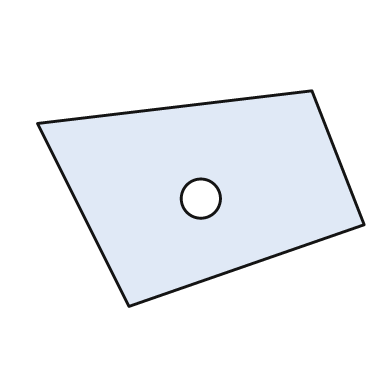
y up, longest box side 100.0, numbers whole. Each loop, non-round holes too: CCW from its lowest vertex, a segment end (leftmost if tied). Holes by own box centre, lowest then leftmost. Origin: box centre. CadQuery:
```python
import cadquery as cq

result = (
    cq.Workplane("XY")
    .moveTo(-22.0, -33.0)
    .lineTo(50.0, -8.0)
    .lineTo(34.0, 33.0)
    .lineTo(-50.0, 23.0)
    .close()
    .moveTo(0.0, 0.0)
    .circle(6.0)
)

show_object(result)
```